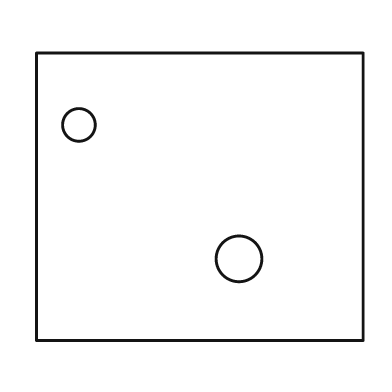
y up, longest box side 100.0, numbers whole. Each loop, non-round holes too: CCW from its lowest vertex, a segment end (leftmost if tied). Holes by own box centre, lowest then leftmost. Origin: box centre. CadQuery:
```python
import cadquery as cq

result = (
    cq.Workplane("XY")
    .moveTo(-50.0, -44.0)
    .lineTo(50.0, -44.0)
    .lineTo(50.0, 44.0)
    .lineTo(-50.0, 44.0)
    .close()
    .moveTo(12.0, -19.0)
    .circle(7.0)
    .moveTo(-37.0, 22.0)
    .circle(5.0)
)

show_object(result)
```